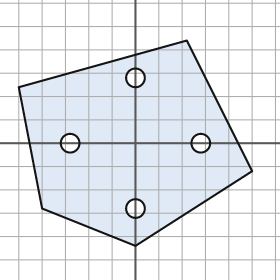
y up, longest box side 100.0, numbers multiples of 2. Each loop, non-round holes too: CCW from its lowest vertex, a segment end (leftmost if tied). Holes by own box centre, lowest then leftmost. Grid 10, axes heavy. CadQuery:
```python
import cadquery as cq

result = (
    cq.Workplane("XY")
    .moveTo(0.0, -44.0)
    .lineTo(50.0, -12.0)
    .lineTo(22.0, 44.0)
    .lineTo(-50.0, 24.0)
    .lineTo(-40.0, -28.0)
    .close()
    .moveTo(0.0, -28.0)
    .circle(4.0)
    .moveTo(-28.0, 0.0)
    .circle(4.0)
    .moveTo(28.0, 0.0)
    .circle(4.0)
    .moveTo(0.0, 28.0)
    .circle(4.0)
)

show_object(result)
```